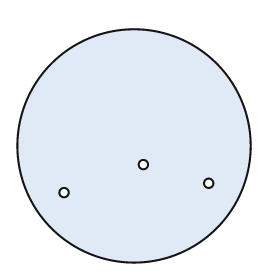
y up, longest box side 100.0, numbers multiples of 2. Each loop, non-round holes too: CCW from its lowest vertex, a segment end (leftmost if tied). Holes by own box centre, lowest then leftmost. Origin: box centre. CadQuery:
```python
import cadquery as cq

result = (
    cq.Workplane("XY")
    .moveTo(0.0, 0.0)
    .circle(50.0)
    .moveTo(-30.0, -20.0)
    .circle(2.0)
    .moveTo(32.0, -16.0)
    .circle(2.0)
    .moveTo(4.0, -8.0)
    .circle(2.0)
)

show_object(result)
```